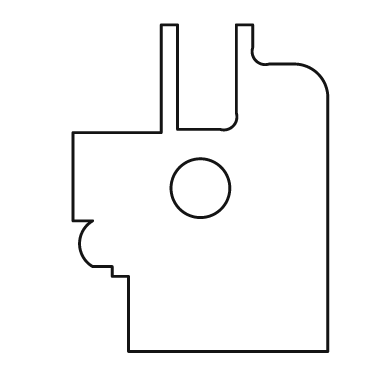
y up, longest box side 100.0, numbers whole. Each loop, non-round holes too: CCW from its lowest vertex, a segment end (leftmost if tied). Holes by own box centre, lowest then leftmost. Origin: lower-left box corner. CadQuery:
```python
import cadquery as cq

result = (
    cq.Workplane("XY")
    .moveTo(17.0, 0.0)
    .lineTo(78.0, 0.0)
    .lineTo(78.0, 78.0)
    .threePointArc((75.0, 85.0), (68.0, 88.0))
    .lineTo(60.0, 88.0)
    .threePointArc((56.0, 89.0), (55.0, 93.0))
    .lineTo(55.0, 100.0)
    .lineTo(50.0, 100.0)
    .lineTo(50.0, 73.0)
    .threePointArc((49.0, 69.0), (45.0, 68.0))
    .lineTo(32.0, 68.0)
    .lineTo(32.0, 100.0)
    .lineTo(27.0, 100.0)
    .lineTo(27.0, 67.0)
    .lineTo(0.0, 67.0)
    .lineTo(0.0, 40.0)
    .lineTo(6.0, 40.0)
    .threePointArc((2.0, 33.0), (6.0, 26.0))
    .lineTo(12.0, 26.0)
    .lineTo(12.0, 23.0)
    .lineTo(17.0, 23.0)
    .close()
    .moveTo(39.0, 50.0)
    .circle(9.0)
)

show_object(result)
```